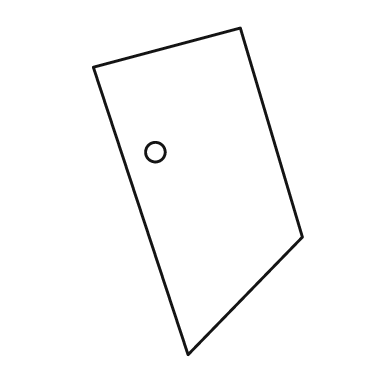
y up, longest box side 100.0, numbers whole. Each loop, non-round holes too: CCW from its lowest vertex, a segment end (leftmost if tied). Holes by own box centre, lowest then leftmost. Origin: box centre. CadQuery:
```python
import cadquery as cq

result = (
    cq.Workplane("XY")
    .moveTo(-3.0, -50.0)
    .lineTo(32.0, -14.0)
    .lineTo(13.0, 50.0)
    .lineTo(-32.0, 38.0)
    .close()
    .moveTo(-13.0, 12.0)
    .circle(3.0)
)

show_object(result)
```